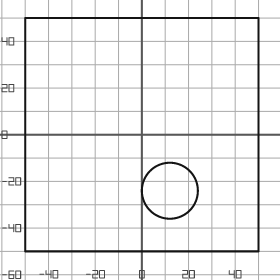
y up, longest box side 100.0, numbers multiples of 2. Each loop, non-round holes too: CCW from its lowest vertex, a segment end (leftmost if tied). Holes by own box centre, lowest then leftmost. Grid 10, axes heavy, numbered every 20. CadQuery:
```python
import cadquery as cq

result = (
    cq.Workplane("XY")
    .moveTo(-50.0, -50.0)
    .lineTo(50.0, -50.0)
    .lineTo(50.0, 50.0)
    .lineTo(-50.0, 50.0)
    .close()
    .moveTo(12.0, -24.0)
    .circle(12.0)
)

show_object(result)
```